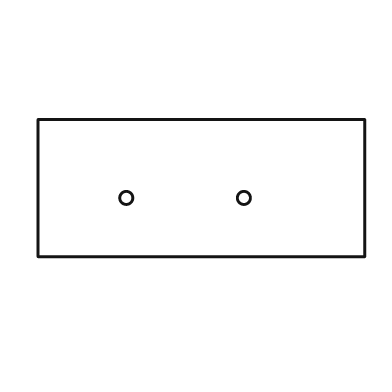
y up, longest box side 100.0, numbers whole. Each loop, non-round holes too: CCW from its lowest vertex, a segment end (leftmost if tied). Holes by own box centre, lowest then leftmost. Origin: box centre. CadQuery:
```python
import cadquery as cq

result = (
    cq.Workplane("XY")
    .moveTo(-50.0, -21.0)
    .lineTo(50.0, -21.0)
    .lineTo(50.0, 21.0)
    .lineTo(-50.0, 21.0)
    .close()
    .moveTo(-23.0, -3.0)
    .circle(2.0)
    .moveTo(13.0, -3.0)
    .circle(2.0)
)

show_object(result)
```